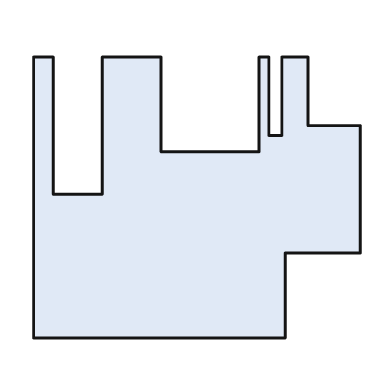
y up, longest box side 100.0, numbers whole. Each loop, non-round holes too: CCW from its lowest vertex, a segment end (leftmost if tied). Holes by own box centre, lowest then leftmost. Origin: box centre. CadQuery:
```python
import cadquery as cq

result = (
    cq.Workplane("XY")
    .moveTo(-50.0, -43.0)
    .lineTo(27.0, -43.0)
    .lineTo(27.0, -17.0)
    .lineTo(50.0, -17.0)
    .lineTo(50.0, 22.0)
    .lineTo(34.0, 22.0)
    .lineTo(34.0, 43.0)
    .lineTo(26.0, 43.0)
    .lineTo(26.0, 19.0)
    .lineTo(22.0, 19.0)
    .lineTo(22.0, 43.0)
    .lineTo(19.0, 43.0)
    .lineTo(19.0, 14.0)
    .lineTo(-11.0, 14.0)
    .lineTo(-11.0, 43.0)
    .lineTo(-29.0, 43.0)
    .lineTo(-29.0, 1.0)
    .lineTo(-44.0, 1.0)
    .lineTo(-44.0, 43.0)
    .lineTo(-50.0, 43.0)
    .close()
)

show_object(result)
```